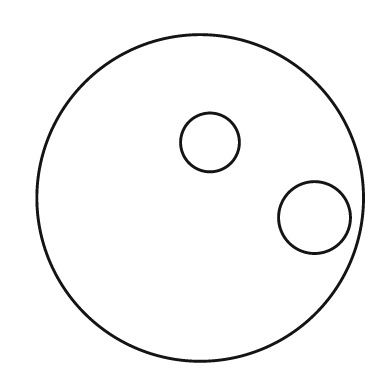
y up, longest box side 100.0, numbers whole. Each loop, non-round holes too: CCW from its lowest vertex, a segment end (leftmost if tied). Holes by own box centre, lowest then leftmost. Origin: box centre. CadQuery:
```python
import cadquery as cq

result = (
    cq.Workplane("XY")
    .moveTo(0.0, 0.0)
    .circle(50.0)
    .moveTo(35.0, -6.0)
    .circle(11.0)
    .moveTo(3.0, 17.0)
    .circle(9.0)
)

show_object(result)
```